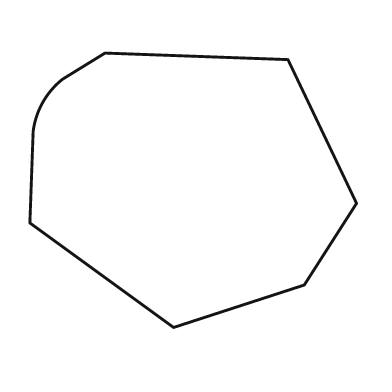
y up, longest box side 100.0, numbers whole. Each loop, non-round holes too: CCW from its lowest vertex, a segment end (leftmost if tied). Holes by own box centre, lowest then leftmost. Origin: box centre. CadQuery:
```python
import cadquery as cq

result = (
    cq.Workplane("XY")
    .moveTo(-6.0, -42.0)
    .lineTo(34.0, -29.0)
    .lineTo(50.0, -4.0)
    .lineTo(29.0, 40.0)
    .lineTo(-27.0, 42.0)
    .lineTo(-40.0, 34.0)
    .threePointArc((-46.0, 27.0), (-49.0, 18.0))
    .lineTo(-50.0, -10.0)
    .close()
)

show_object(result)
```